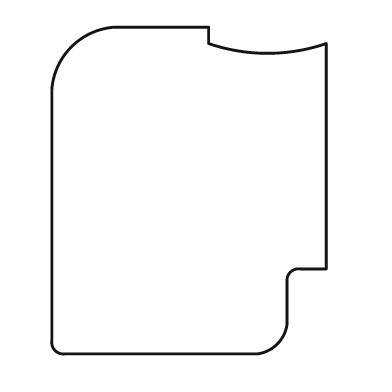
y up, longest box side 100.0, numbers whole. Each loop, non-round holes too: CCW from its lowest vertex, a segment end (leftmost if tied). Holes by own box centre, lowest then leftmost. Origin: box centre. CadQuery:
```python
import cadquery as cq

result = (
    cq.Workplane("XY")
    .moveTo(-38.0, -50.0)
    .lineTo(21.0, -50.0)
    .threePointArc((27.0, -47.0), (30.0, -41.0))
    .lineTo(30.0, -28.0)
    .threePointArc((31.0, -25.0), (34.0, -24.0))
    .lineTo(42.0, -24.0)
    .lineTo(42.0, 45.0)
    .threePointArc((24.0, 42.0), (6.0, 45.0))
    .lineTo(6.0, 50.0)
    .lineTo(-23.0, 50.0)
    .threePointArc((-36.0, 44.0), (-42.0, 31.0))
    .lineTo(-42.0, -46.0)
    .threePointArc((-41.0, -49.0), (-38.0, -50.0))
    .close()
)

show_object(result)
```